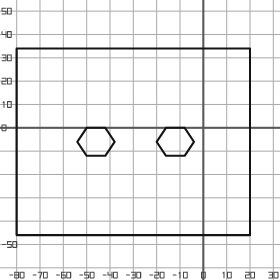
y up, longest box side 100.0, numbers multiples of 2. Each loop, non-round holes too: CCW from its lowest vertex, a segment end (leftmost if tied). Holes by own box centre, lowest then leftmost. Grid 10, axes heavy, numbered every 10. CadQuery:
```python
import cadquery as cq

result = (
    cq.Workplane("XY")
    .moveTo(-80.0, -46.0)
    .lineTo(20.0, -46.0)
    .lineTo(20.0, 34.0)
    .lineTo(-80.0, 34.0)
    .close()
    .moveTo(-50.0, -12.0)
    .lineTo(-42.0, -12.0)
    .lineTo(-38.0, -6.0)
    .lineTo(-42.0, 0.0)
    .lineTo(-50.0, 0.0)
    .lineTo(-54.0, -6.0)
    .close()
    .moveTo(-16.0, -12.0)
    .lineTo(-8.0, -12.0)
    .lineTo(-4.0, -6.0)
    .lineTo(-8.0, 0.0)
    .lineTo(-16.0, 0.0)
    .lineTo(-20.0, -6.0)
    .close()
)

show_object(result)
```